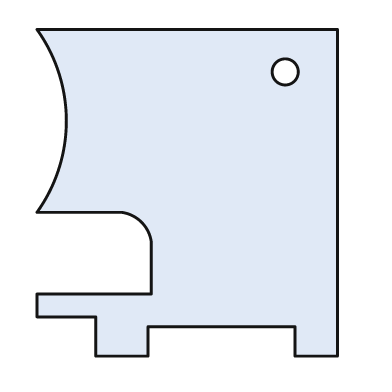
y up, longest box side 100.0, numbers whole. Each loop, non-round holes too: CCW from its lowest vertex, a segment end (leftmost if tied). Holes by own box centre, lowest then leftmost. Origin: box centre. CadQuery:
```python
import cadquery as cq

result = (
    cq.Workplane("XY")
    .moveTo(-28.0, -50.0)
    .lineTo(-12.0, -50.0)
    .lineTo(-12.0, -41.0)
    .lineTo(33.0, -41.0)
    .lineTo(33.0, -50.0)
    .lineTo(46.0, -50.0)
    .lineTo(46.0, 50.0)
    .lineTo(-46.0, 50.0)
    .threePointArc((-37.0, 22.0), (-46.0, -6.0))
    .lineTo(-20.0, -6.0)
    .threePointArc((-14.0, -9.0), (-11.0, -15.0))
    .lineTo(-11.0, -31.0)
    .lineTo(-46.0, -31.0)
    .lineTo(-46.0, -38.0)
    .lineTo(-28.0, -38.0)
    .close()
    .moveTo(30.0, 37.0)
    .circle(4.0)
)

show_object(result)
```